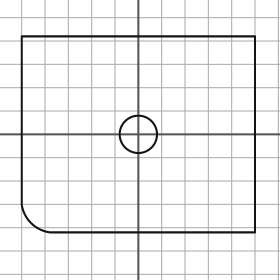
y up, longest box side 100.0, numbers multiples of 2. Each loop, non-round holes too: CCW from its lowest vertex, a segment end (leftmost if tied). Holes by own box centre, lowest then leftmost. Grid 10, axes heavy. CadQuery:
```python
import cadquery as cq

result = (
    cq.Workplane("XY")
    .moveTo(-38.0, -42.0)
    .lineTo(50.0, -42.0)
    .lineTo(50.0, 42.0)
    .lineTo(-50.0, 42.0)
    .lineTo(-50.0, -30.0)
    .threePointArc((-46.0, -38.0), (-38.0, -42.0))
    .close()
    .moveTo(0.0, 0.0)
    .circle(8.0)
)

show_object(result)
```